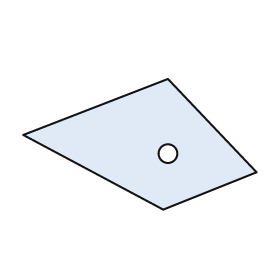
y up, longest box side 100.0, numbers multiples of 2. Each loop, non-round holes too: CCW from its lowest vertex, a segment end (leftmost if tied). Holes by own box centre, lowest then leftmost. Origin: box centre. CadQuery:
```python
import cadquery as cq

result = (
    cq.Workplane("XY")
    .moveTo(10.0, -28.0)
    .lineTo(50.0, -12.0)
    .lineTo(12.0, 28.0)
    .lineTo(-50.0, 4.0)
    .close()
    .moveTo(12.0, -4.0)
    .circle(4.0)
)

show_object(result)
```